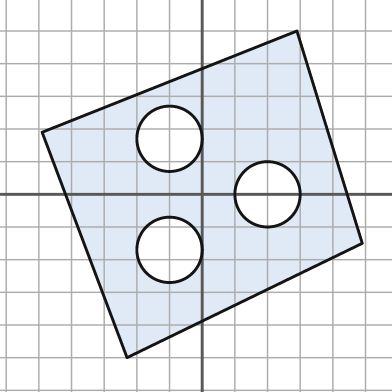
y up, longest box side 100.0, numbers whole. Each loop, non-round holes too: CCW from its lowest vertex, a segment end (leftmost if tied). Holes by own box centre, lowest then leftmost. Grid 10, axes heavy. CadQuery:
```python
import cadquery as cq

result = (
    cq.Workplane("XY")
    .moveTo(-23.0, -50.0)
    .lineTo(49.0, -15.0)
    .lineTo(29.0, 50.0)
    .lineTo(-49.0, 19.0)
    .close()
    .moveTo(-10.0, -17.0)
    .circle(10.0)
    .moveTo(20.0, 0.0)
    .circle(10.0)
    .moveTo(-10.0, 17.0)
    .circle(10.0)
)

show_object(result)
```